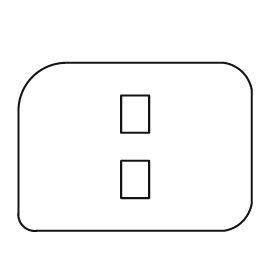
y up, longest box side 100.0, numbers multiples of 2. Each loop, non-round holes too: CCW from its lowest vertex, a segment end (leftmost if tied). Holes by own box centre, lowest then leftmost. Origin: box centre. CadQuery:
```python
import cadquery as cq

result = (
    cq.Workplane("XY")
    .moveTo(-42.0, -36.0)
    .lineTo(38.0, -36.0)
    .threePointArc((46.0, -32.0), (50.0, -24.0))
    .lineTo(50.0, 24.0)
    .threePointArc((46.0, 32.0), (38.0, 36.0))
    .lineTo(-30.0, 36.0)
    .threePointArc((-44.0, 30.0), (-50.0, 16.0))
    .lineTo(-50.0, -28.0)
    .threePointArc((-48.0, -34.0), (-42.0, -36.0))
    .close()
    .moveTo(-6.0, -22.0)
    .lineTo(6.0, -22.0)
    .lineTo(6.0, -6.0)
    .lineTo(-6.0, -6.0)
    .close()
    .moveTo(-6.0, 6.0)
    .lineTo(6.0, 6.0)
    .lineTo(6.0, 22.0)
    .lineTo(-6.0, 22.0)
    .close()
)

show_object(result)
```